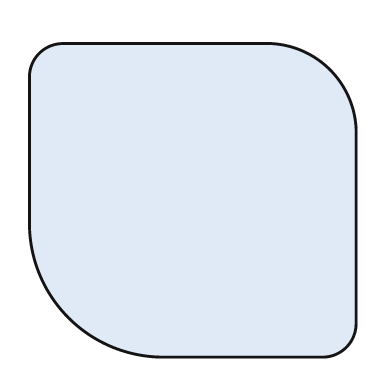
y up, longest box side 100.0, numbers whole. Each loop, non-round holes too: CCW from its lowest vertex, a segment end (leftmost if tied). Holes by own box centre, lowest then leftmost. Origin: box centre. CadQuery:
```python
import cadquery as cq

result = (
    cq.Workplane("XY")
    .moveTo(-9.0, -48.0)
    .lineTo(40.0, -48.0)
    .threePointArc((47.0, -45.0), (50.0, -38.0))
    .lineTo(50.0, 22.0)
    .threePointArc((42.0, 40.0), (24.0, 48.0))
    .lineTo(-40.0, 48.0)
    .threePointArc((-47.0, 45.0), (-50.0, 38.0))
    .lineTo(-50.0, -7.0)
    .threePointArc((-38.0, -36.0), (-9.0, -48.0))
    .close()
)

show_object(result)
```